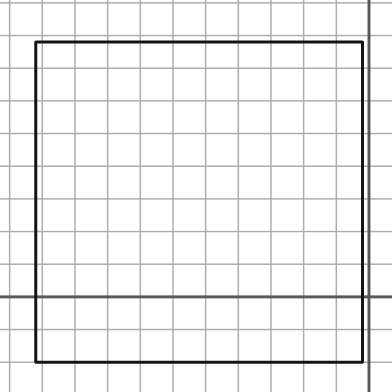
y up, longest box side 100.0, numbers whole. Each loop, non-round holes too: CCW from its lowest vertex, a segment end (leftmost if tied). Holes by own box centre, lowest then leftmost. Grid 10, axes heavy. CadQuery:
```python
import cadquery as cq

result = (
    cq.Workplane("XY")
    .moveTo(-102.0, -20.0)
    .lineTo(-2.0, -20.0)
    .lineTo(-2.0, 78.0)
    .lineTo(-102.0, 78.0)
    .close()
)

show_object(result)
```